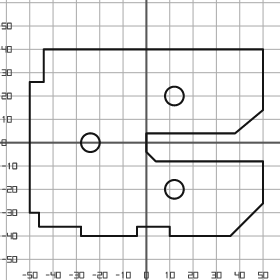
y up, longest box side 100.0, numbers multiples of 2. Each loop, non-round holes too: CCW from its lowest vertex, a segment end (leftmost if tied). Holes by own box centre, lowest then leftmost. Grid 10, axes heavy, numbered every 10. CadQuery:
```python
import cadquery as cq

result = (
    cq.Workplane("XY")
    .moveTo(-28.0, -40.0)
    .lineTo(-4.0, -40.0)
    .lineTo(-4.0, -36.0)
    .lineTo(10.0, -36.0)
    .lineTo(10.0, -40.0)
    .lineTo(36.0, -40.0)
    .lineTo(50.0, -26.0)
    .lineTo(50.0, -8.0)
    .lineTo(4.0, -8.0)
    .lineTo(0.0, -4.0)
    .lineTo(0.0, 4.0)
    .lineTo(38.0, 4.0)
    .lineTo(50.0, 14.0)
    .lineTo(50.0, 40.0)
    .lineTo(-44.0, 40.0)
    .lineTo(-44.0, 26.0)
    .lineTo(-50.0, 26.0)
    .lineTo(-50.0, -30.0)
    .lineTo(-46.0, -30.0)
    .lineTo(-46.0, -36.0)
    .lineTo(-28.0, -36.0)
    .close()
    .moveTo(12.0, -20.0)
    .circle(4.0)
    .moveTo(-24.0, 0.0)
    .circle(4.0)
    .moveTo(12.0, 20.0)
    .circle(4.0)
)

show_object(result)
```